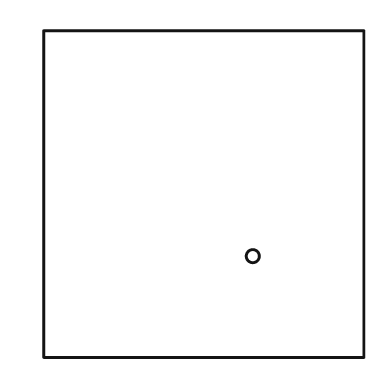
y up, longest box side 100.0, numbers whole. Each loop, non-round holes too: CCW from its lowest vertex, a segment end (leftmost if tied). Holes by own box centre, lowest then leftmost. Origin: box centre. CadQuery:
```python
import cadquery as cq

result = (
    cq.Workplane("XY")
    .moveTo(-49.0, -50.0)
    .lineTo(49.0, -50.0)
    .lineTo(49.0, 50.0)
    .lineTo(-49.0, 50.0)
    .close()
    .moveTo(15.0, -19.0)
    .circle(2.0)
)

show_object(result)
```